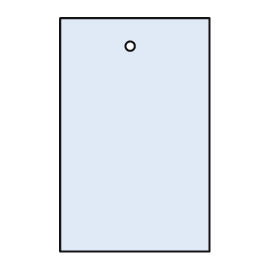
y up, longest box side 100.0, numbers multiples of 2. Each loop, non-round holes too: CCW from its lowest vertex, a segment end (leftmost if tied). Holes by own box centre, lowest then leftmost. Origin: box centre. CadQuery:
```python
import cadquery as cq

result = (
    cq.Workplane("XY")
    .moveTo(-32.0, -50.0)
    .lineTo(32.0, -50.0)
    .lineTo(32.0, 50.0)
    .lineTo(-32.0, 50.0)
    .close()
    .moveTo(-2.0, 38.0)
    .circle(2.0)
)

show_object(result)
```